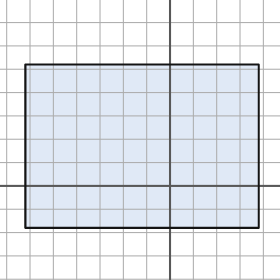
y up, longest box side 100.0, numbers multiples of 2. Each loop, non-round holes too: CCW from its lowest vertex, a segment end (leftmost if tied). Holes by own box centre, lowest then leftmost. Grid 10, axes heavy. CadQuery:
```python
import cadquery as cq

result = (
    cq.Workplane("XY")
    .moveTo(-62.0, -18.0)
    .lineTo(38.0, -18.0)
    .lineTo(38.0, 52.0)
    .lineTo(-62.0, 52.0)
    .close()
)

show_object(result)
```